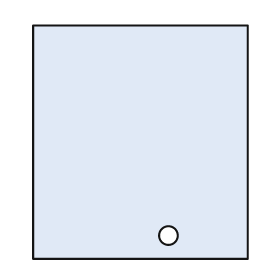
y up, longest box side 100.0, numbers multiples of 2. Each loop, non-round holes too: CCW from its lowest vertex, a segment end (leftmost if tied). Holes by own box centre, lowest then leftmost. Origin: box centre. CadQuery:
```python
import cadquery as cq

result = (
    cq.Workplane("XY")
    .moveTo(-46.0, -50.0)
    .lineTo(46.0, -50.0)
    .lineTo(46.0, 50.0)
    .lineTo(-46.0, 50.0)
    .close()
    .moveTo(12.0, -40.0)
    .circle(4.0)
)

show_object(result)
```